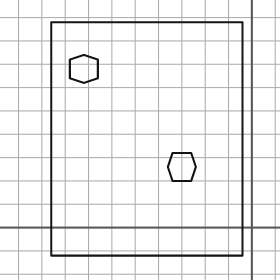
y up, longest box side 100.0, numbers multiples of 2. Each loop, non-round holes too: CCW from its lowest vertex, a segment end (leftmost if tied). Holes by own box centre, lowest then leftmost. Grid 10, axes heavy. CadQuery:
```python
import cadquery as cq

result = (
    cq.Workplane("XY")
    .moveTo(-86.0, -12.0)
    .lineTo(-4.0, -12.0)
    .lineTo(-4.0, 88.0)
    .lineTo(-86.0, 88.0)
    .close()
    .moveTo(-34.0, 20.0)
    .lineTo(-26.0, 20.0)
    .lineTo(-24.0, 26.0)
    .lineTo(-26.0, 32.0)
    .lineTo(-34.0, 32.0)
    .lineTo(-36.0, 26.0)
    .close()
    .moveTo(-72.0, 62.0)
    .lineTo(-66.0, 64.0)
    .lineTo(-66.0, 72.0)
    .lineTo(-72.0, 74.0)
    .lineTo(-78.0, 72.0)
    .lineTo(-78.0, 64.0)
    .close()
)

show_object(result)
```